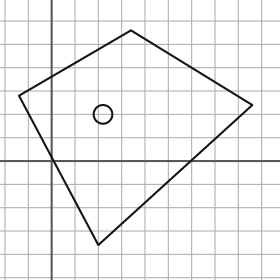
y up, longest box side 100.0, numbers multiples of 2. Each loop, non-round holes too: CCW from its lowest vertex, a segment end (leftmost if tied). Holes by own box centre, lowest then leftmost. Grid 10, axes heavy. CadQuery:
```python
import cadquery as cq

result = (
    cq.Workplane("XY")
    .moveTo(20.0, -36.0)
    .lineTo(86.0, 24.0)
    .lineTo(34.0, 56.0)
    .lineTo(-14.0, 28.0)
    .close()
    .moveTo(22.0, 20.0)
    .circle(4.0)
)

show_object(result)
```